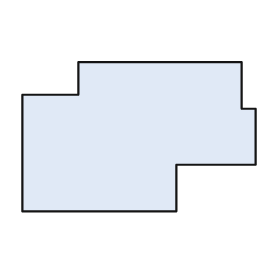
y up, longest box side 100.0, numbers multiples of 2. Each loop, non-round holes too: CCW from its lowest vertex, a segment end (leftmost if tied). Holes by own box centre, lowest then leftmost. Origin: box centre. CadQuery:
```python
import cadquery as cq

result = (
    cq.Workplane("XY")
    .moveTo(-50.0, -32.0)
    .lineTo(16.0, -32.0)
    .lineTo(16.0, -12.0)
    .lineTo(50.0, -12.0)
    .lineTo(50.0, 12.0)
    .lineTo(44.0, 12.0)
    .lineTo(44.0, 32.0)
    .lineTo(-26.0, 32.0)
    .lineTo(-26.0, 18.0)
    .lineTo(-50.0, 18.0)
    .close()
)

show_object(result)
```